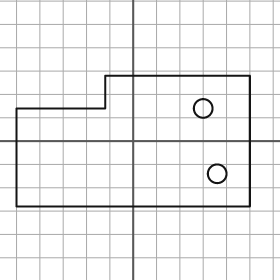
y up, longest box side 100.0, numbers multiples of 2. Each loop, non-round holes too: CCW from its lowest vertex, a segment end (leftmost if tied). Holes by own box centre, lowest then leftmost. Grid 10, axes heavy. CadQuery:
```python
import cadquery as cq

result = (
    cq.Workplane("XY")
    .moveTo(-50.0, -28.0)
    .lineTo(50.0, -28.0)
    .lineTo(50.0, 28.0)
    .lineTo(-12.0, 28.0)
    .lineTo(-12.0, 14.0)
    .lineTo(-50.0, 14.0)
    .close()
    .moveTo(36.0, -14.0)
    .circle(4.0)
    .moveTo(30.0, 14.0)
    .circle(4.0)
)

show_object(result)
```